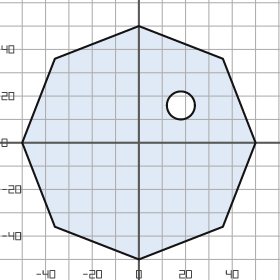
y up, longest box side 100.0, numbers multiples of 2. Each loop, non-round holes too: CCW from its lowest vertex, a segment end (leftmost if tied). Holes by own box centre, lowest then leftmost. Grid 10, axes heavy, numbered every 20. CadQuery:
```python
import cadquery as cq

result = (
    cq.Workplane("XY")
    .moveTo(0.0, -50.0)
    .lineTo(36.0, -36.0)
    .lineTo(50.0, 0.0)
    .lineTo(36.0, 36.0)
    .lineTo(0.0, 50.0)
    .lineTo(-36.0, 36.0)
    .lineTo(-50.0, 0.0)
    .lineTo(-36.0, -36.0)
    .close()
    .moveTo(18.0, 16.0)
    .circle(6.0)
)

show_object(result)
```